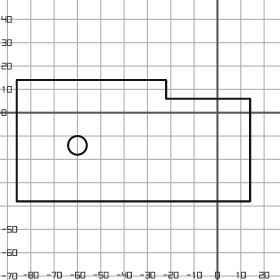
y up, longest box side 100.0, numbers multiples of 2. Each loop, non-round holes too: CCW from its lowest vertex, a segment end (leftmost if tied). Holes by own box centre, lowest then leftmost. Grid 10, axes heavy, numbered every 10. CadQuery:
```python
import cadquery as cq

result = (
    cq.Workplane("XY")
    .moveTo(-86.0, -38.0)
    .lineTo(14.0, -38.0)
    .lineTo(14.0, 6.0)
    .lineTo(-22.0, 6.0)
    .lineTo(-22.0, 14.0)
    .lineTo(-86.0, 14.0)
    .close()
    .moveTo(-60.0, -14.0)
    .circle(4.0)
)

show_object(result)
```